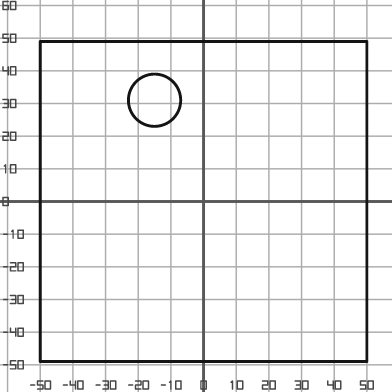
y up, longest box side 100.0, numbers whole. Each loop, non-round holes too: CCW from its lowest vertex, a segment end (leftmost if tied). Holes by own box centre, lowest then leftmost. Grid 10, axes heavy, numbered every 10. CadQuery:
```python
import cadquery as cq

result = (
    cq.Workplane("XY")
    .moveTo(-50.0, -49.0)
    .lineTo(50.0, -49.0)
    .lineTo(50.0, 49.0)
    .lineTo(-50.0, 49.0)
    .close()
    .moveTo(-15.0, 31.0)
    .circle(8.0)
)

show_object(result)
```